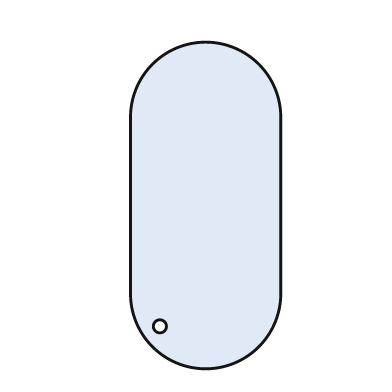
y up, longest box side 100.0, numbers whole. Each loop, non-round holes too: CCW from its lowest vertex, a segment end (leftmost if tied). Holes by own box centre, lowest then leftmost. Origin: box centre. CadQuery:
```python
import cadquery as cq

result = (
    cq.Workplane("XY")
    .moveTo(-23.0, -27.0)
    .threePointArc((0.0, -50.0), (23.0, -27.0))
    .lineTo(23.0, 27.0)
    .threePointArc((0.0, 50.0), (-23.0, 27.0))
    .close()
    .moveTo(-14.0, -37.0)
    .circle(2.0)
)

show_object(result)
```